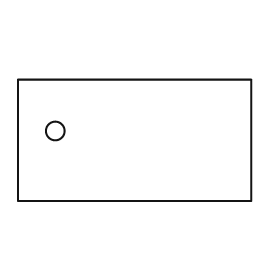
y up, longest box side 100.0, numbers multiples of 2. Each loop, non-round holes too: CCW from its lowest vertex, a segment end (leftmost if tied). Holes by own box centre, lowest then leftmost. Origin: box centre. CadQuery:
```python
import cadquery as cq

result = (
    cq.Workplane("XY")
    .moveTo(-50.0, -26.0)
    .lineTo(50.0, -26.0)
    .lineTo(50.0, 26.0)
    .lineTo(-50.0, 26.0)
    .close()
    .moveTo(-34.0, 4.0)
    .circle(4.0)
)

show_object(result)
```